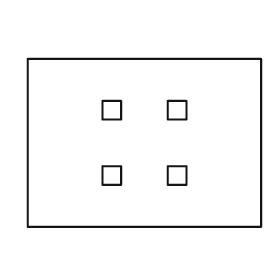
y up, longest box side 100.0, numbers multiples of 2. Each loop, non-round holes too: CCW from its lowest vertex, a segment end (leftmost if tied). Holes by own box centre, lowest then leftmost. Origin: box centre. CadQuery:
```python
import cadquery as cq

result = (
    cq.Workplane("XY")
    .moveTo(-50.0, -36.0)
    .lineTo(50.0, -36.0)
    .lineTo(50.0, 36.0)
    .lineTo(-50.0, 36.0)
    .close()
    .moveTo(-18.0, -18.0)
    .lineTo(-10.0, -18.0)
    .lineTo(-10.0, -10.0)
    .lineTo(-18.0, -10.0)
    .close()
    .moveTo(10.0, -18.0)
    .lineTo(18.0, -18.0)
    .lineTo(18.0, -10.0)
    .lineTo(10.0, -10.0)
    .close()
    .moveTo(-18.0, 10.0)
    .lineTo(-10.0, 10.0)
    .lineTo(-10.0, 18.0)
    .lineTo(-18.0, 18.0)
    .close()
    .moveTo(10.0, 10.0)
    .lineTo(18.0, 10.0)
    .lineTo(18.0, 18.0)
    .lineTo(10.0, 18.0)
    .close()
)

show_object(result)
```